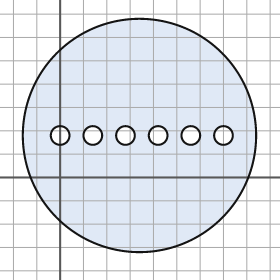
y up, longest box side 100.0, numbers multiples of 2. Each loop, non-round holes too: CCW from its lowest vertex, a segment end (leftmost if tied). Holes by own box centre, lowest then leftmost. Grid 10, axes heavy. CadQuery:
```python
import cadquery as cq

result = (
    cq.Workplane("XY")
    .moveTo(34.0, 18.0)
    .circle(50.0)
    .moveTo(0.0, 18.0)
    .circle(4.0)
    .moveTo(14.0, 18.0)
    .circle(4.0)
    .moveTo(28.0, 18.0)
    .circle(4.0)
    .moveTo(42.0, 18.0)
    .circle(4.0)
    .moveTo(56.0, 18.0)
    .circle(4.0)
    .moveTo(70.0, 18.0)
    .circle(4.0)
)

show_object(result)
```